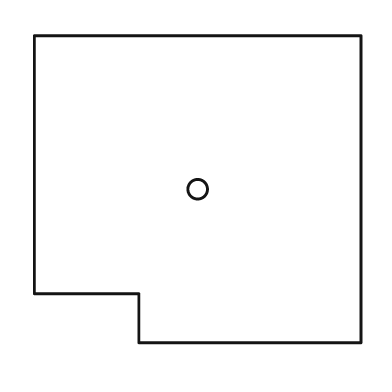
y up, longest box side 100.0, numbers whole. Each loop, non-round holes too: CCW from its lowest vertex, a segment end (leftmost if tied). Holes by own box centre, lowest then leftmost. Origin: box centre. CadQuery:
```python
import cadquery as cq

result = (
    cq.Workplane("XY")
    .moveTo(-18.0, -47.0)
    .lineTo(50.0, -47.0)
    .lineTo(50.0, 47.0)
    .lineTo(-50.0, 47.0)
    .lineTo(-50.0, -32.0)
    .lineTo(-18.0, -32.0)
    .close()
    .moveTo(0.0, 0.0)
    .circle(3.0)
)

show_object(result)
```